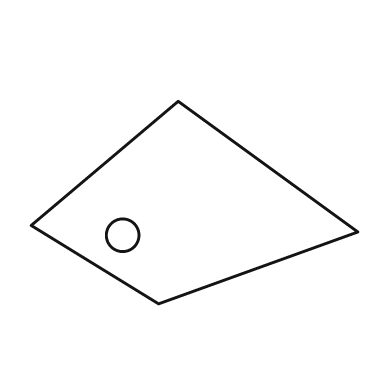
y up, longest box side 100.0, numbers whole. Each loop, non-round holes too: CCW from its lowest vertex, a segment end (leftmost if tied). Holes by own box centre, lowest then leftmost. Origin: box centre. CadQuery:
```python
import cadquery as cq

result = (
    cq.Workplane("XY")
    .moveTo(-11.0, -31.0)
    .lineTo(50.0, -9.0)
    .lineTo(-5.0, 31.0)
    .lineTo(-50.0, -7.0)
    .close()
    .moveTo(-22.0, -10.0)
    .circle(5.0)
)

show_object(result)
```